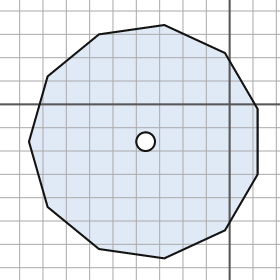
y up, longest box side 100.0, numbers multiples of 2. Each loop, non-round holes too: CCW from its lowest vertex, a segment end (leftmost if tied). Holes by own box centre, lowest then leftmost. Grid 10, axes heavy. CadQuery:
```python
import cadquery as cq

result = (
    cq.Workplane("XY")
    .moveTo(-28.0, -66.0)
    .lineTo(-2.0, -54.0)
    .lineTo(12.0, -30.0)
    .lineTo(12.0, -2.0)
    .lineTo(-2.0, 22.0)
    .lineTo(-28.0, 34.0)
    .lineTo(-56.0, 30.0)
    .lineTo(-78.0, 12.0)
    .lineTo(-86.0, -16.0)
    .lineTo(-78.0, -44.0)
    .lineTo(-56.0, -62.0)
    .close()
    .moveTo(-36.0, -16.0)
    .circle(4.0)
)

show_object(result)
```